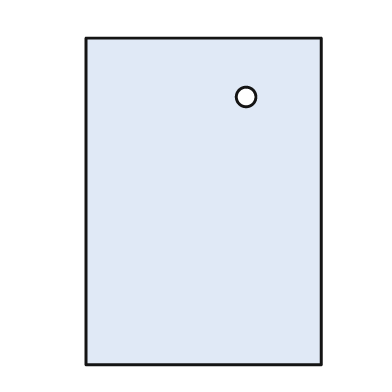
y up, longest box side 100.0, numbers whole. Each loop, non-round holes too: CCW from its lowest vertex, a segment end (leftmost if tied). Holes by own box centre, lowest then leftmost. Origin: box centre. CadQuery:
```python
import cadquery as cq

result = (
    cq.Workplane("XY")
    .moveTo(-36.0, -50.0)
    .lineTo(36.0, -50.0)
    .lineTo(36.0, 50.0)
    .lineTo(-36.0, 50.0)
    .close()
    .moveTo(13.0, 32.0)
    .circle(3.0)
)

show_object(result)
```